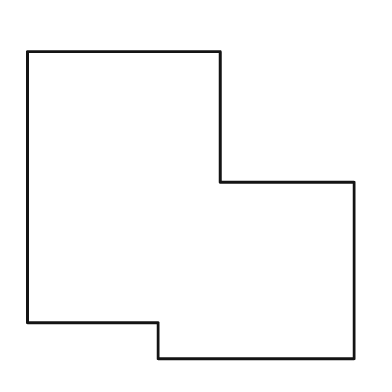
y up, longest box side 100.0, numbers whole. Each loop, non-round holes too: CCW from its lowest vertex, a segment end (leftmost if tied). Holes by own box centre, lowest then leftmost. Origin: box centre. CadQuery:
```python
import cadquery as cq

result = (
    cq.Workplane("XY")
    .moveTo(-10.0, -47.0)
    .lineTo(50.0, -47.0)
    .lineTo(50.0, 7.0)
    .lineTo(9.0, 7.0)
    .lineTo(9.0, 47.0)
    .lineTo(-50.0, 47.0)
    .lineTo(-50.0, -36.0)
    .lineTo(-10.0, -36.0)
    .close()
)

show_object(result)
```